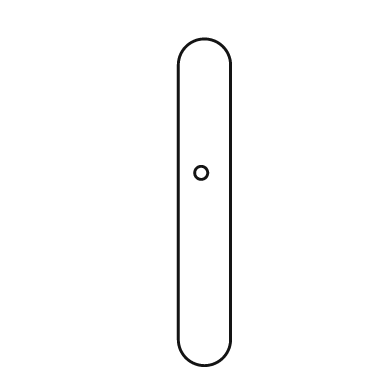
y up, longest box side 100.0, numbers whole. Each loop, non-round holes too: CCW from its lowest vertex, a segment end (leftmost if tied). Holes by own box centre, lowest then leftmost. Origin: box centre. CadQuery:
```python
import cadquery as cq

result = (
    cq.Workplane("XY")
    .moveTo(-8.0, -42.0)
    .threePointArc((0.0, -50.0), (8.0, -42.0))
    .lineTo(8.0, 42.0)
    .threePointArc((0.0, 50.0), (-8.0, 42.0))
    .close()
    .moveTo(-1.0, 9.0)
    .circle(2.0)
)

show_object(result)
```